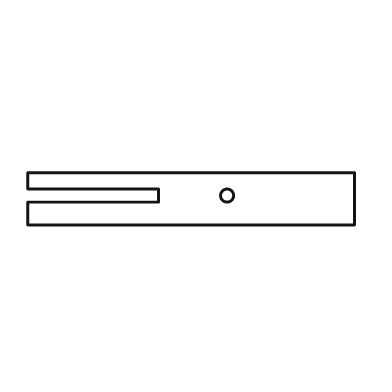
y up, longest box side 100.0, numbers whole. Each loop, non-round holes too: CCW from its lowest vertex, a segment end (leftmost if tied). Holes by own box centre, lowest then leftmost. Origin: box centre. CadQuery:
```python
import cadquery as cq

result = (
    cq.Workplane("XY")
    .moveTo(-50.0, -8.0)
    .lineTo(50.0, -8.0)
    .lineTo(50.0, 8.0)
    .lineTo(-50.0, 8.0)
    .lineTo(-50.0, 3.0)
    .lineTo(-10.0, 3.0)
    .lineTo(-10.0, -1.0)
    .lineTo(-50.0, -1.0)
    .close()
    .moveTo(11.0, 1.0)
    .circle(2.0)
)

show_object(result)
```